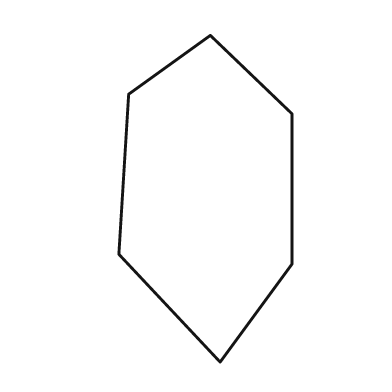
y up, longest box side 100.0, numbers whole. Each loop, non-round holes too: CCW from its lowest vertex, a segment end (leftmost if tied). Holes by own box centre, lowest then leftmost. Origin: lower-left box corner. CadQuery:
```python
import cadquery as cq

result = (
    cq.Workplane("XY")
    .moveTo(31.0, 0.0)
    .lineTo(53.0, 30.0)
    .lineTo(53.0, 76.0)
    .lineTo(28.0, 100.0)
    .lineTo(3.0, 82.0)
    .lineTo(0.0, 33.0)
    .close()
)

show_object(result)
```